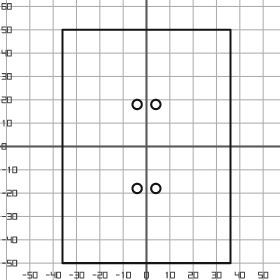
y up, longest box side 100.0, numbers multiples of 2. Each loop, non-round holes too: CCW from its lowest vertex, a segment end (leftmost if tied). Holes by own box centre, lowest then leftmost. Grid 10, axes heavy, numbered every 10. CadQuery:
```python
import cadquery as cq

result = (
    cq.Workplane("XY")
    .moveTo(-36.0, -50.0)
    .lineTo(36.0, -50.0)
    .lineTo(36.0, 50.0)
    .lineTo(-36.0, 50.0)
    .close()
    .moveTo(-4.0, -18.0)
    .circle(2.0)
    .moveTo(4.0, -18.0)
    .circle(2.0)
    .moveTo(-4.0, 18.0)
    .circle(2.0)
    .moveTo(4.0, 18.0)
    .circle(2.0)
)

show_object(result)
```